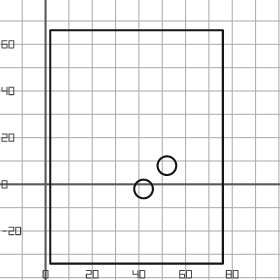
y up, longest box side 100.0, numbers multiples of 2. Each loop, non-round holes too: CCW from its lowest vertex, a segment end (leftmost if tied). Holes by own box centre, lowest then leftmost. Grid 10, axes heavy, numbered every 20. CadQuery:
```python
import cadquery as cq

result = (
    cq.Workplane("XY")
    .moveTo(2.0, -34.0)
    .lineTo(76.0, -34.0)
    .lineTo(76.0, 66.0)
    .lineTo(2.0, 66.0)
    .close()
    .moveTo(42.0, -2.0)
    .circle(4.0)
    .moveTo(52.0, 8.0)
    .circle(4.0)
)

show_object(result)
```